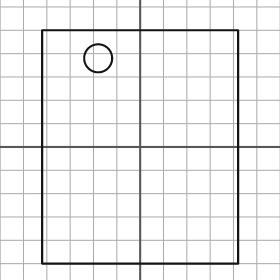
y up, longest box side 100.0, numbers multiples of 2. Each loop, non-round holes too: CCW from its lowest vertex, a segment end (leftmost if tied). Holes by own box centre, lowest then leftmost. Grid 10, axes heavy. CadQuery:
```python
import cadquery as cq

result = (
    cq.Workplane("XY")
    .moveTo(-42.0, -50.0)
    .lineTo(42.0, -50.0)
    .lineTo(42.0, 50.0)
    .lineTo(-42.0, 50.0)
    .close()
    .moveTo(-18.0, 38.0)
    .circle(6.0)
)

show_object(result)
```